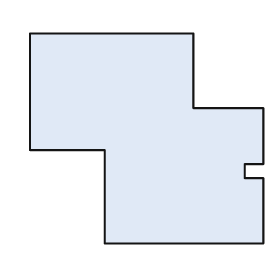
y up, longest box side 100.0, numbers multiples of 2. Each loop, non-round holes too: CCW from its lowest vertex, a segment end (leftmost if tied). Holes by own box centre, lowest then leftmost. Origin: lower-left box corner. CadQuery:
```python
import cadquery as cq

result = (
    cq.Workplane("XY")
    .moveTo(32.0, 0.0)
    .lineTo(100.0, 0.0)
    .lineTo(100.0, 28.0)
    .lineTo(92.0, 28.0)
    .lineTo(92.0, 34.0)
    .lineTo(100.0, 34.0)
    .lineTo(100.0, 58.0)
    .lineTo(70.0, 58.0)
    .lineTo(70.0, 90.0)
    .lineTo(0.0, 90.0)
    .lineTo(0.0, 40.0)
    .lineTo(32.0, 40.0)
    .close()
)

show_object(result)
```